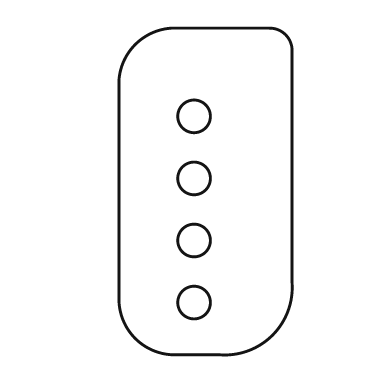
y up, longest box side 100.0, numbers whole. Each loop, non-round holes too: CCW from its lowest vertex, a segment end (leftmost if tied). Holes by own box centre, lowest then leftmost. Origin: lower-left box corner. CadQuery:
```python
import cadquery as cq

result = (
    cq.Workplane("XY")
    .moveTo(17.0, 0.0)
    .lineTo(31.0, 0.0)
    .threePointArc((47.0, 6.0), (53.0, 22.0))
    .lineTo(53.0, 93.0)
    .threePointArc((51.0, 98.0), (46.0, 100.0))
    .lineTo(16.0, 100.0)
    .threePointArc((5.0, 95.0), (0.0, 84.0))
    .lineTo(0.0, 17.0)
    .threePointArc((5.0, 5.0), (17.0, 0.0))
    .close()
    .moveTo(23.0, 16.0)
    .circle(5.0)
    .moveTo(23.0, 35.0)
    .circle(5.0)
    .moveTo(23.0, 54.0)
    .circle(5.0)
    .moveTo(23.0, 73.0)
    .circle(5.0)
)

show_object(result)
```